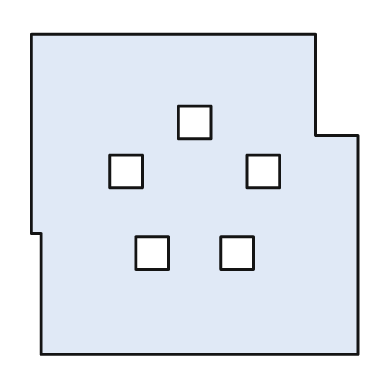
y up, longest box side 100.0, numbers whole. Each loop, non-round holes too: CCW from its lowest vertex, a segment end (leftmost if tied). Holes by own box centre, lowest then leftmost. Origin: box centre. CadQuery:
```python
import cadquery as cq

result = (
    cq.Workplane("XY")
    .moveTo(-47.0, -49.0)
    .lineTo(50.0, -49.0)
    .lineTo(50.0, 18.0)
    .lineTo(37.0, 18.0)
    .lineTo(37.0, 49.0)
    .lineTo(-50.0, 49.0)
    .lineTo(-50.0, -12.0)
    .lineTo(-47.0, -12.0)
    .close()
    .moveTo(-18.0, -23.0)
    .lineTo(-8.0, -23.0)
    .lineTo(-8.0, -13.0)
    .lineTo(-18.0, -13.0)
    .close()
    .moveTo(8.0, -23.0)
    .lineTo(18.0, -23.0)
    .lineTo(18.0, -13.0)
    .lineTo(8.0, -13.0)
    .close()
    .moveTo(-26.0, 2.0)
    .lineTo(-16.0, 2.0)
    .lineTo(-16.0, 12.0)
    .lineTo(-26.0, 12.0)
    .close()
    .moveTo(16.0, 2.0)
    .lineTo(26.0, 2.0)
    .lineTo(26.0, 12.0)
    .lineTo(16.0, 12.0)
    .close()
    .moveTo(-5.0, 17.0)
    .lineTo(5.0, 17.0)
    .lineTo(5.0, 27.0)
    .lineTo(-5.0, 27.0)
    .close()
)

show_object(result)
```